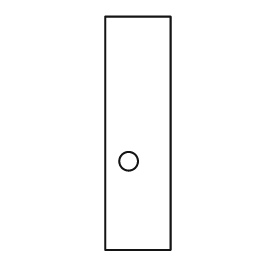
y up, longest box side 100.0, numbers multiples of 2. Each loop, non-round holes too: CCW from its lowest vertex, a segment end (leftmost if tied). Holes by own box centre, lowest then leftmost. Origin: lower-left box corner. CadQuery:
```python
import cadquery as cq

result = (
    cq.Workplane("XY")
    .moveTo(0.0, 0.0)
    .lineTo(28.0, 0.0)
    .lineTo(28.0, 100.0)
    .lineTo(0.0, 100.0)
    .close()
    .moveTo(10.0, 38.0)
    .circle(4.0)
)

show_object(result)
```